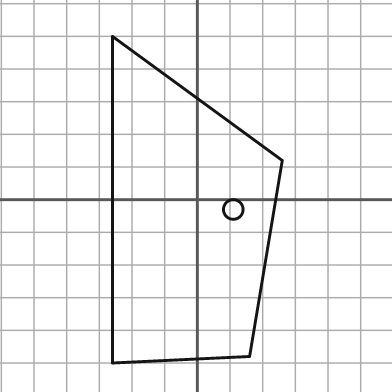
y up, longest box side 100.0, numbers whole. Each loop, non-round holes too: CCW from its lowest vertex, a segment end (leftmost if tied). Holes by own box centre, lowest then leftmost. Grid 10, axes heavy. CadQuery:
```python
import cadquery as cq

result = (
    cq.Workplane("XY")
    .moveTo(-26.0, -50.0)
    .lineTo(16.0, -48.0)
    .lineTo(26.0, 12.0)
    .lineTo(-26.0, 50.0)
    .close()
    .moveTo(11.0, -3.0)
    .circle(3.0)
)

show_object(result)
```